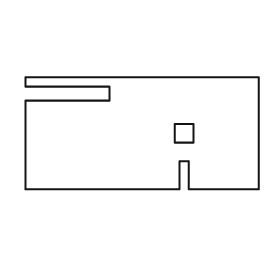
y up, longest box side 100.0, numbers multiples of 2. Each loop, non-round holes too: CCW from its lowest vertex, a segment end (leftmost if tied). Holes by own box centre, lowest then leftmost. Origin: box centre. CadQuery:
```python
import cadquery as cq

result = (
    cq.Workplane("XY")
    .moveTo(-50.0, -24.0)
    .lineTo(16.0, -24.0)
    .lineTo(16.0, -12.0)
    .lineTo(20.0, -12.0)
    .lineTo(20.0, -24.0)
    .lineTo(50.0, -24.0)
    .lineTo(50.0, 24.0)
    .lineTo(-50.0, 24.0)
    .lineTo(-50.0, 20.0)
    .lineTo(-14.0, 20.0)
    .lineTo(-14.0, 14.0)
    .lineTo(-50.0, 14.0)
    .close()
    .moveTo(14.0, -4.0)
    .lineTo(22.0, -4.0)
    .lineTo(22.0, 4.0)
    .lineTo(14.0, 4.0)
    .close()
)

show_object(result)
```